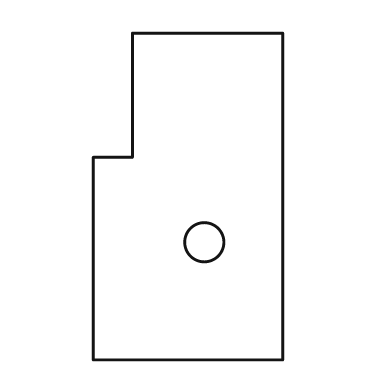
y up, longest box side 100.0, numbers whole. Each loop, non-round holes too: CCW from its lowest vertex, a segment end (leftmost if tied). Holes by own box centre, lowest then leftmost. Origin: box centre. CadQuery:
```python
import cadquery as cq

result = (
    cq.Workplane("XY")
    .moveTo(-29.0, -50.0)
    .lineTo(29.0, -50.0)
    .lineTo(29.0, 50.0)
    .lineTo(-17.0, 50.0)
    .lineTo(-17.0, 12.0)
    .lineTo(-29.0, 12.0)
    .close()
    .moveTo(5.0, -14.0)
    .circle(6.0)
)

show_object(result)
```